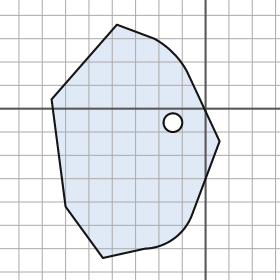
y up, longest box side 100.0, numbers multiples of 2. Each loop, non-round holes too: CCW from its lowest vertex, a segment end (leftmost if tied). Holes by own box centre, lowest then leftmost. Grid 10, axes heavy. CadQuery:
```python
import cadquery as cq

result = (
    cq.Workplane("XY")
    .moveTo(-44.0, -64.0)
    .lineTo(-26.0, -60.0)
    .threePointArc((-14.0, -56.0), (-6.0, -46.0))
    .lineTo(6.0, -14.0)
    .lineTo(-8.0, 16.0)
    .threePointArc((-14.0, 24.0), (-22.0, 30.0))
    .lineTo(-38.0, 36.0)
    .lineTo(-66.0, 4.0)
    .lineTo(-60.0, -42.0)
    .close()
    .moveTo(-14.0, -6.0)
    .circle(4.0)
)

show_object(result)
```